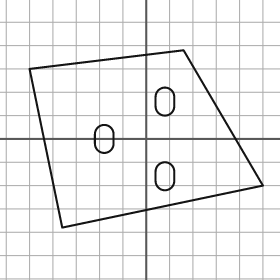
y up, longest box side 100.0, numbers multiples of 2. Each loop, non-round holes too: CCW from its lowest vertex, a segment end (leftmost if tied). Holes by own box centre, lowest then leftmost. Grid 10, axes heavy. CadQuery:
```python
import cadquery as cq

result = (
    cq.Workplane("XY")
    .moveTo(-36.0, -38.0)
    .lineTo(50.0, -20.0)
    .lineTo(16.0, 38.0)
    .lineTo(-50.0, 30.0)
    .close()
    .moveTo(4.0, -18.0)
    .threePointArc((8.0, -22.0), (12.0, -18.0))
    .lineTo(12.0, -14.0)
    .threePointArc((8.0, -10.0), (4.0, -14.0))
    .close()
    .moveTo(-22.0, -2.0)
    .threePointArc((-18.0, -6.0), (-14.0, -2.0))
    .lineTo(-14.0, 2.0)
    .threePointArc((-18.0, 6.0), (-22.0, 2.0))
    .close()
    .moveTo(4.0, 14.0)
    .threePointArc((8.0, 10.0), (12.0, 14.0))
    .lineTo(12.0, 18.0)
    .threePointArc((8.0, 22.0), (4.0, 18.0))
    .close()
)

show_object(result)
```